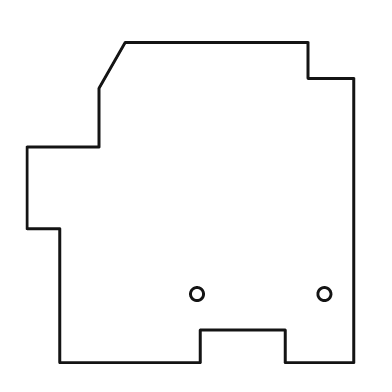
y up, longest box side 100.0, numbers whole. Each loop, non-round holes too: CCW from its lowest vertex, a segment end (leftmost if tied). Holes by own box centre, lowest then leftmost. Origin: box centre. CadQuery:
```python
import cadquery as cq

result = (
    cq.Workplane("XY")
    .moveTo(-40.0, -49.0)
    .lineTo(3.0, -49.0)
    .lineTo(3.0, -39.0)
    .lineTo(29.0, -39.0)
    .lineTo(29.0, -49.0)
    .lineTo(50.0, -49.0)
    .lineTo(50.0, 38.0)
    .lineTo(36.0, 38.0)
    .lineTo(36.0, 49.0)
    .lineTo(-20.0, 49.0)
    .lineTo(-28.0, 35.0)
    .lineTo(-28.0, 17.0)
    .lineTo(-50.0, 17.0)
    .lineTo(-50.0, -8.0)
    .lineTo(-40.0, -8.0)
    .close()
    .moveTo(2.0, -28.0)
    .circle(2.0)
    .moveTo(41.0, -28.0)
    .circle(2.0)
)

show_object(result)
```